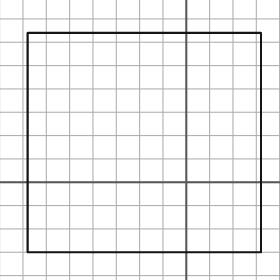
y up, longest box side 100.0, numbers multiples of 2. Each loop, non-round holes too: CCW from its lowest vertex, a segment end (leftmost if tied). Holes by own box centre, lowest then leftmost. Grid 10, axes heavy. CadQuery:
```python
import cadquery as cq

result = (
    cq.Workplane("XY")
    .moveTo(-68.0, -30.0)
    .lineTo(32.0, -30.0)
    .lineTo(32.0, 64.0)
    .lineTo(-68.0, 64.0)
    .close()
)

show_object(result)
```